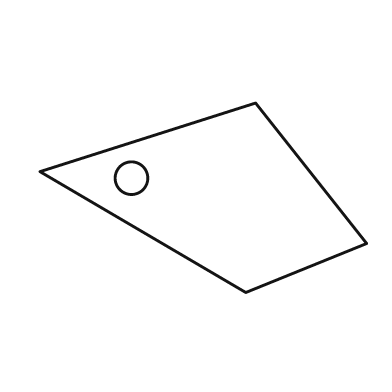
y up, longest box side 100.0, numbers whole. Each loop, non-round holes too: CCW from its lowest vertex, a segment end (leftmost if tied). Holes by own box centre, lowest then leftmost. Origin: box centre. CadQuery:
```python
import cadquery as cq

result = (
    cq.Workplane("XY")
    .moveTo(13.0, -29.0)
    .lineTo(50.0, -14.0)
    .lineTo(16.0, 29.0)
    .lineTo(-50.0, 8.0)
    .close()
    .moveTo(-22.0, 6.0)
    .circle(5.0)
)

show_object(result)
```